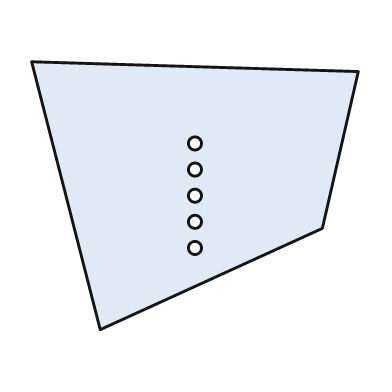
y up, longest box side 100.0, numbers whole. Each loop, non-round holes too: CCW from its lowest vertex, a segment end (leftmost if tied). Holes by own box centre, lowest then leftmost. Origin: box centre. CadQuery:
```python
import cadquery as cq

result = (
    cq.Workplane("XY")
    .moveTo(-29.0, -41.0)
    .lineTo(39.0, -10.0)
    .lineTo(50.0, 38.0)
    .lineTo(-50.0, 41.0)
    .close()
    .moveTo(0.0, -16.0)
    .circle(2.0)
    .moveTo(0.0, -8.0)
    .circle(2.0)
    .moveTo(0.0, 0.0)
    .circle(2.0)
    .moveTo(0.0, 8.0)
    .circle(2.0)
    .moveTo(0.0, 16.0)
    .circle(2.0)
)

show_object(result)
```